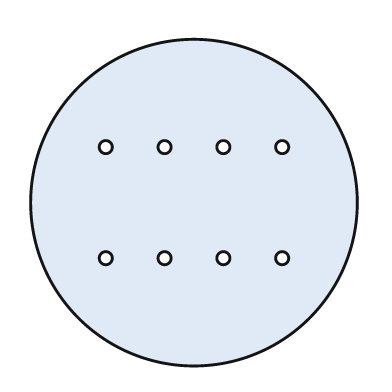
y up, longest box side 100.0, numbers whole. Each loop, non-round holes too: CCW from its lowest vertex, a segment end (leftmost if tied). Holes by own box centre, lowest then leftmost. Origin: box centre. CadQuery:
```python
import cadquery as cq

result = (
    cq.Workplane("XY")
    .moveTo(0.0, 0.0)
    .circle(50.0)
    .moveTo(-27.0, -17.0)
    .circle(2.0)
    .moveTo(-9.0, -17.0)
    .circle(2.0)
    .moveTo(9.0, -17.0)
    .circle(2.0)
    .moveTo(27.0, -17.0)
    .circle(2.0)
    .moveTo(-27.0, 17.0)
    .circle(2.0)
    .moveTo(-9.0, 17.0)
    .circle(2.0)
    .moveTo(9.0, 17.0)
    .circle(2.0)
    .moveTo(27.0, 17.0)
    .circle(2.0)
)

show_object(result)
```